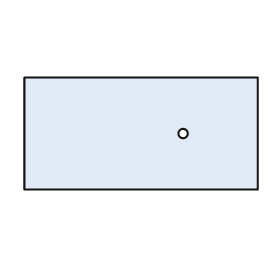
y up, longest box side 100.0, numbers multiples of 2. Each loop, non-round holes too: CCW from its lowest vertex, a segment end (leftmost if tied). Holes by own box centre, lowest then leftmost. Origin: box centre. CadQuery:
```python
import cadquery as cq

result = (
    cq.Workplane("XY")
    .moveTo(-50.0, -24.0)
    .lineTo(50.0, -24.0)
    .lineTo(50.0, 24.0)
    .lineTo(-50.0, 24.0)
    .close()
    .moveTo(18.0, 0.0)
    .circle(2.0)
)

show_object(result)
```